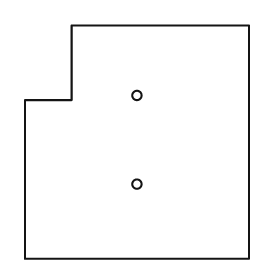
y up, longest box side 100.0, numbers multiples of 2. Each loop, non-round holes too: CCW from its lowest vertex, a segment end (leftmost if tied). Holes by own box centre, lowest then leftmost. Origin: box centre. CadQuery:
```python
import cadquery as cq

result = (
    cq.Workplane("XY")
    .moveTo(-48.0, -50.0)
    .lineTo(48.0, -50.0)
    .lineTo(48.0, 50.0)
    .lineTo(-28.0, 50.0)
    .lineTo(-28.0, 18.0)
    .lineTo(-48.0, 18.0)
    .close()
    .moveTo(0.0, -18.0)
    .circle(2.0)
    .moveTo(0.0, 20.0)
    .circle(2.0)
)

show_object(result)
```